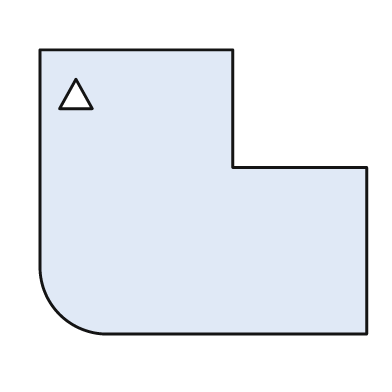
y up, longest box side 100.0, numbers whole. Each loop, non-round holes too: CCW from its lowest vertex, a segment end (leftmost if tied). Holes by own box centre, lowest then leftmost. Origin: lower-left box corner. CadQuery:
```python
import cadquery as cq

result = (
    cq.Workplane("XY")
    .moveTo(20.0, 0.0)
    .lineTo(100.0, 0.0)
    .lineTo(100.0, 51.0)
    .lineTo(59.0, 51.0)
    .lineTo(59.0, 87.0)
    .lineTo(0.0, 87.0)
    .lineTo(0.0, 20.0)
    .threePointArc((6.0, 6.0), (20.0, 0.0))
    .close()
    .moveTo(6.0, 69.0)
    .lineTo(16.0, 69.0)
    .lineTo(11.0, 78.0)
    .close()
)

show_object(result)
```